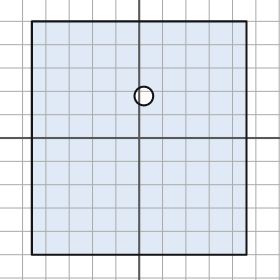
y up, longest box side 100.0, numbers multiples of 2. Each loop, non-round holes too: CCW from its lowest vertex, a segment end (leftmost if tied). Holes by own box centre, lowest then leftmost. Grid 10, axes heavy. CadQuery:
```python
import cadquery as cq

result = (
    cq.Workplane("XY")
    .moveTo(-46.0, -50.0)
    .lineTo(46.0, -50.0)
    .lineTo(46.0, 50.0)
    .lineTo(-46.0, 50.0)
    .close()
    .moveTo(2.0, 18.0)
    .circle(4.0)
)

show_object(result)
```